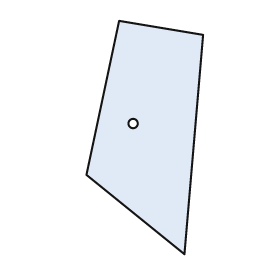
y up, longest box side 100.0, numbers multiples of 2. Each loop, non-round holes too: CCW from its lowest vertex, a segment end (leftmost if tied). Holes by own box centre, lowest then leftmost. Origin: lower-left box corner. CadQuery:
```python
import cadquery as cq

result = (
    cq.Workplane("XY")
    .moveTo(42.0, 0.0)
    .lineTo(50.0, 94.0)
    .lineTo(14.0, 100.0)
    .lineTo(0.0, 34.0)
    .close()
    .moveTo(20.0, 56.0)
    .circle(2.0)
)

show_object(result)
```